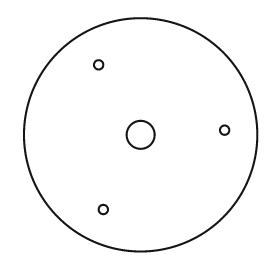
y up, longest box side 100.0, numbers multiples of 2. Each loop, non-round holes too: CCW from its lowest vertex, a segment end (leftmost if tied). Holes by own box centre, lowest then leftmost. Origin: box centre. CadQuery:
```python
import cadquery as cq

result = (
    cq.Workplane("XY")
    .moveTo(0.0, 0.0)
    .circle(50.0)
    .moveTo(-16.0, -32.0)
    .circle(2.0)
    .moveTo(0.0, 0.0)
    .circle(6.0)
    .moveTo(36.0, 2.0)
    .circle(2.0)
    .moveTo(-18.0, 30.0)
    .circle(2.0)
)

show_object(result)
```